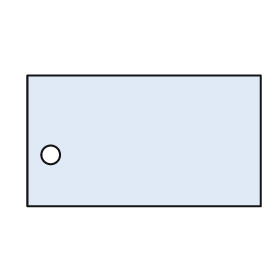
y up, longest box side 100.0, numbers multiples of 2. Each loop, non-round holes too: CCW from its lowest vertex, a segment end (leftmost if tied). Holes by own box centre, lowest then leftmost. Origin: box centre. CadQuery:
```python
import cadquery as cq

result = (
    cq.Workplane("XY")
    .moveTo(-50.0, -28.0)
    .lineTo(50.0, -28.0)
    .lineTo(50.0, 28.0)
    .lineTo(-50.0, 28.0)
    .close()
    .moveTo(-40.0, -6.0)
    .circle(4.0)
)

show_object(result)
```